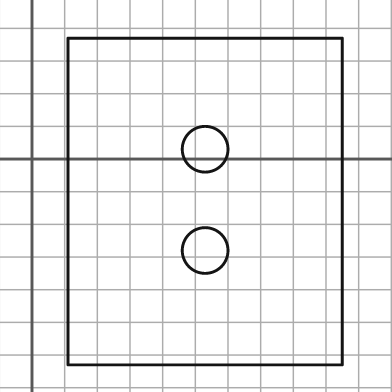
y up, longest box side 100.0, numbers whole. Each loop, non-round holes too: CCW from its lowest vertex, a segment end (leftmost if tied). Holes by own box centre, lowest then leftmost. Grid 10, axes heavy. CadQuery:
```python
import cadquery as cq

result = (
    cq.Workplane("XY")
    .moveTo(11.0, -63.0)
    .lineTo(95.0, -63.0)
    .lineTo(95.0, 37.0)
    .lineTo(11.0, 37.0)
    .close()
    .moveTo(53.0, -28.0)
    .circle(7.0)
    .moveTo(53.0, 3.0)
    .circle(7.0)
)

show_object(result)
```